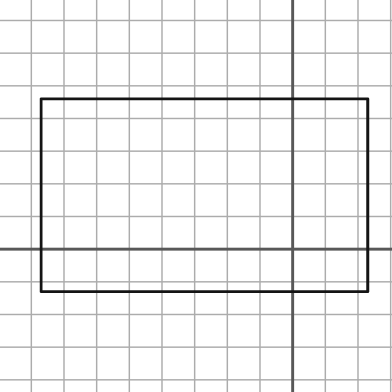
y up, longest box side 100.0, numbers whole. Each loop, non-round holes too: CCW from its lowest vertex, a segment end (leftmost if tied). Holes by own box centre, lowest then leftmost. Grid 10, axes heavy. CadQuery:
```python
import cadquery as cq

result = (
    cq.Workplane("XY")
    .moveTo(-77.0, -13.0)
    .lineTo(23.0, -13.0)
    .lineTo(23.0, 46.0)
    .lineTo(-77.0, 46.0)
    .close()
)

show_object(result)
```